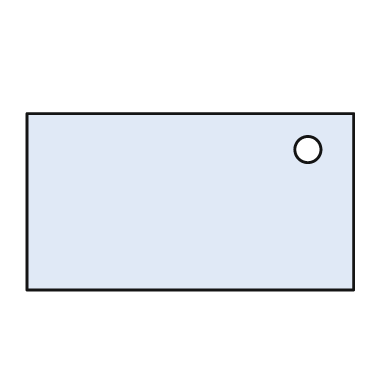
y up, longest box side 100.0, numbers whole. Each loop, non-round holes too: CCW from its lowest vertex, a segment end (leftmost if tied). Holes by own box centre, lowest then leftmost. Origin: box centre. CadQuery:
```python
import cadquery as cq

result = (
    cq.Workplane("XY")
    .moveTo(-50.0, -27.0)
    .lineTo(50.0, -27.0)
    .lineTo(50.0, 27.0)
    .lineTo(-50.0, 27.0)
    .close()
    .moveTo(36.0, 16.0)
    .circle(4.0)
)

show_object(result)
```